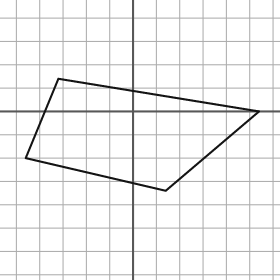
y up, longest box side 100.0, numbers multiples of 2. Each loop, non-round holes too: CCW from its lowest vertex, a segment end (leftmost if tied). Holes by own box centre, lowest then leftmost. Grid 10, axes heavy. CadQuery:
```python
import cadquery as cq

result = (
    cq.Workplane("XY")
    .moveTo(14.0, -34.0)
    .lineTo(54.0, 0.0)
    .lineTo(-32.0, 14.0)
    .lineTo(-46.0, -20.0)
    .close()
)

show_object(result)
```